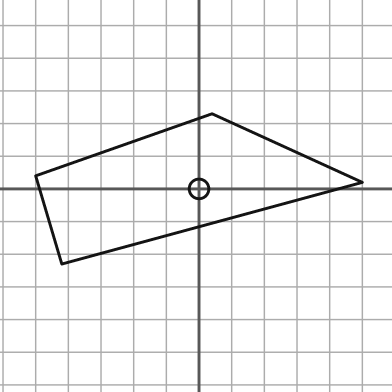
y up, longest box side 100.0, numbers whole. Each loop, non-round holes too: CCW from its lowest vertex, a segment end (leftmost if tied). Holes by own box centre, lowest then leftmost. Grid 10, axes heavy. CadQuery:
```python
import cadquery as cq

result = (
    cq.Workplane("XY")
    .moveTo(-42.0, -23.0)
    .lineTo(50.0, 2.0)
    .lineTo(4.0, 23.0)
    .lineTo(-50.0, 4.0)
    .close()
    .moveTo(0.0, 0.0)
    .circle(3.0)
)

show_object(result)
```